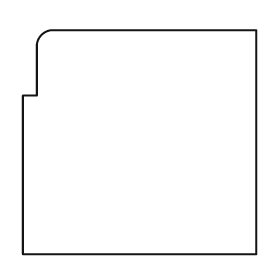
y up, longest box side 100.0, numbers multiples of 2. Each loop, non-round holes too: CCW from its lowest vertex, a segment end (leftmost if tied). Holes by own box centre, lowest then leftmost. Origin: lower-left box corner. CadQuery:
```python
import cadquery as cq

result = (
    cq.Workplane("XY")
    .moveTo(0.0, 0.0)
    .lineTo(100.0, 0.0)
    .lineTo(100.0, 96.0)
    .lineTo(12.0, 96.0)
    .threePointArc((8.0, 94.0), (6.0, 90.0))
    .lineTo(6.0, 68.0)
    .lineTo(0.0, 68.0)
    .close()
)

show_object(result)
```